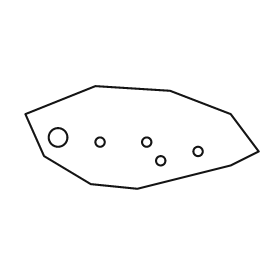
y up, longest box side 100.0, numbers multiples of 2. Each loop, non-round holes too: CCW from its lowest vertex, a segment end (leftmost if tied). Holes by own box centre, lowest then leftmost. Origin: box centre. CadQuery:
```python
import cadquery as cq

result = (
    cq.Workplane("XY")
    .moveTo(-2.0, -22.0)
    .lineTo(38.0, -12.0)
    .lineTo(50.0, -6.0)
    .lineTo(38.0, 10.0)
    .lineTo(12.0, 20.0)
    .lineTo(-20.0, 22.0)
    .lineTo(-50.0, 10.0)
    .lineTo(-42.0, -8.0)
    .lineTo(-22.0, -20.0)
    .close()
    .moveTo(8.0, -10.0)
    .circle(2.0)
    .moveTo(24.0, -6.0)
    .circle(2.0)
    .moveTo(-18.0, -2.0)
    .circle(2.0)
    .moveTo(2.0, -2.0)
    .circle(2.0)
    .moveTo(-36.0, 0.0)
    .circle(4.0)
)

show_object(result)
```